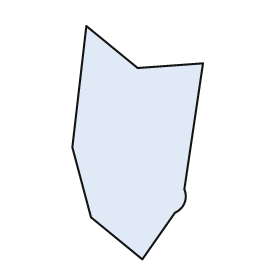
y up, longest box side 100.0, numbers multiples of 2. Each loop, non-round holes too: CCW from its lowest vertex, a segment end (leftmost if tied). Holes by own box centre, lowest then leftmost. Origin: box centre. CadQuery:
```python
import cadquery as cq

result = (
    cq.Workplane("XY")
    .moveTo(2.0, -50.0)
    .lineTo(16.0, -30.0)
    .threePointArc((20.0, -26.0), (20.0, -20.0))
    .lineTo(28.0, 34.0)
    .lineTo(0.0, 32.0)
    .lineTo(-22.0, 50.0)
    .lineTo(-28.0, -2.0)
    .lineTo(-20.0, -32.0)
    .close()
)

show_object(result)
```